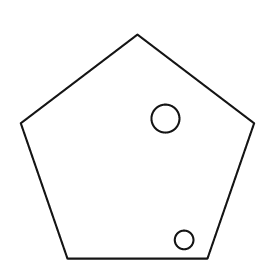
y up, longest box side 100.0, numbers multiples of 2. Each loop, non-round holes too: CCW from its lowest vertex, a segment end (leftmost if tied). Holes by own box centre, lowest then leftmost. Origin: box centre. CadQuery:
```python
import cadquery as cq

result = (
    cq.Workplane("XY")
    .moveTo(-30.0, -48.0)
    .lineTo(30.0, -48.0)
    .lineTo(50.0, 10.0)
    .lineTo(0.0, 48.0)
    .lineTo(-50.0, 10.0)
    .close()
    .moveTo(20.0, -40.0)
    .circle(4.0)
    .moveTo(12.0, 12.0)
    .circle(6.0)
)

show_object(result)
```